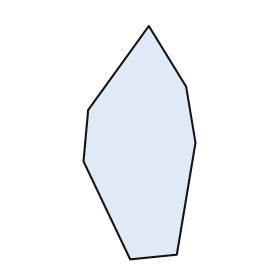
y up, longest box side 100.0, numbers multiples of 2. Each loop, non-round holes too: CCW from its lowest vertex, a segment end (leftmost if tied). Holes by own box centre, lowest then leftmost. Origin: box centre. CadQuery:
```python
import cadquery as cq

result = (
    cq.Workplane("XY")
    .moveTo(-4.0, -50.0)
    .lineTo(16.0, -48.0)
    .lineTo(24.0, 0.0)
    .lineTo(20.0, 24.0)
    .lineTo(4.0, 50.0)
    .lineTo(-22.0, 14.0)
    .lineTo(-24.0, -8.0)
    .close()
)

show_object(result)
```